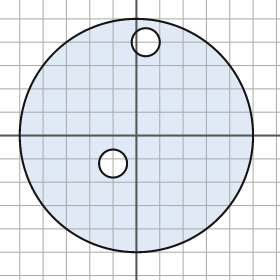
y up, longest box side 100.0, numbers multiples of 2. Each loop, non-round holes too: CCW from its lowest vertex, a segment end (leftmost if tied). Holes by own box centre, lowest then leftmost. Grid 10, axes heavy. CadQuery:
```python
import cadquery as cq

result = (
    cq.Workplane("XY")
    .moveTo(0.0, 0.0)
    .circle(50.0)
    .moveTo(-10.0, -12.0)
    .circle(6.0)
    .moveTo(4.0, 40.0)
    .circle(6.0)
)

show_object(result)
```